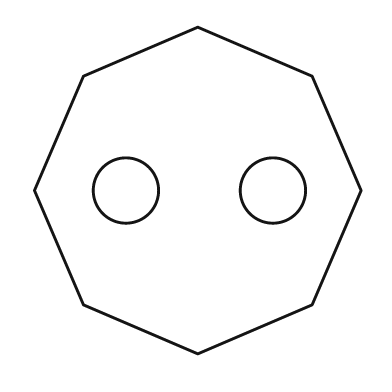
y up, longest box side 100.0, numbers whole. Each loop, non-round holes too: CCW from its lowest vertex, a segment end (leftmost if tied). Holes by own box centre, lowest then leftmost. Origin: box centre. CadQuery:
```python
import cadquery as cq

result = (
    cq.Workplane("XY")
    .moveTo(0.0, -50.0)
    .lineTo(35.0, -35.0)
    .lineTo(50.0, 0.0)
    .lineTo(35.0, 35.0)
    .lineTo(0.0, 50.0)
    .lineTo(-35.0, 35.0)
    .lineTo(-50.0, 0.0)
    .lineTo(-35.0, -35.0)
    .close()
    .moveTo(-22.0, 0.0)
    .circle(10.0)
    .moveTo(23.0, 0.0)
    .circle(10.0)
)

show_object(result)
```